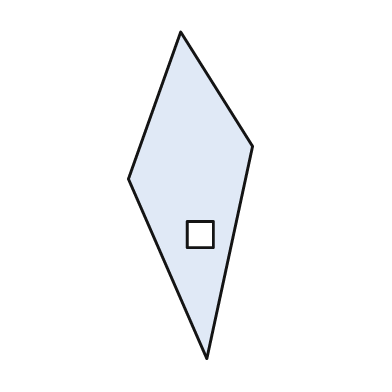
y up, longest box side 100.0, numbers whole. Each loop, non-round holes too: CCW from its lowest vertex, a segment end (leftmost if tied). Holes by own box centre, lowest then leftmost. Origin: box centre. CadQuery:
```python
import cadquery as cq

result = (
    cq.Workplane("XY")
    .moveTo(5.0, -50.0)
    .lineTo(19.0, 15.0)
    .lineTo(-3.0, 50.0)
    .lineTo(-19.0, 5.0)
    .close()
    .moveTo(-1.0, -16.0)
    .lineTo(7.0, -16.0)
    .lineTo(7.0, -8.0)
    .lineTo(-1.0, -8.0)
    .close()
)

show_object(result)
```